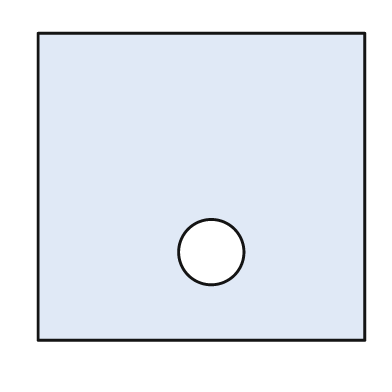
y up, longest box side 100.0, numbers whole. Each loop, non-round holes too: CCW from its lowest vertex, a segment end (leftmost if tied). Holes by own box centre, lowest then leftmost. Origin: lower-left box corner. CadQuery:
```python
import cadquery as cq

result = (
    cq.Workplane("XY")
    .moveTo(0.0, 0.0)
    .lineTo(100.0, 0.0)
    .lineTo(100.0, 94.0)
    .lineTo(0.0, 94.0)
    .close()
    .moveTo(53.0, 27.0)
    .circle(10.0)
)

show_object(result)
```